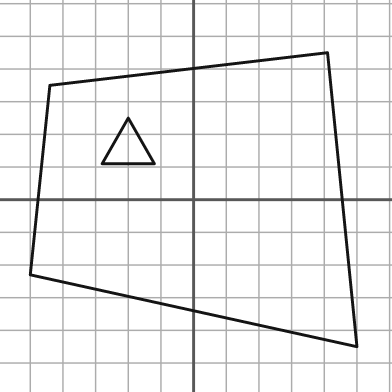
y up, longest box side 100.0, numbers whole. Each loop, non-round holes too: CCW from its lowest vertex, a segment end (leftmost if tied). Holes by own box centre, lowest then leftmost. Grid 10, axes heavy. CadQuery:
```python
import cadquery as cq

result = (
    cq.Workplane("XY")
    .moveTo(50.0, -45.0)
    .lineTo(41.0, 45.0)
    .lineTo(-44.0, 35.0)
    .lineTo(-50.0, -23.0)
    .close()
    .moveTo(-28.0, 11.0)
    .lineTo(-12.0, 11.0)
    .lineTo(-20.0, 25.0)
    .close()
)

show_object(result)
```